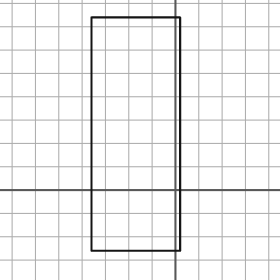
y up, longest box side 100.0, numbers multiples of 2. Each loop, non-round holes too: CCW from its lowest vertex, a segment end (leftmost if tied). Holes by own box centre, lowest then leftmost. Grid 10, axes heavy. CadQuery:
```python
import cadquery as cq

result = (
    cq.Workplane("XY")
    .moveTo(-36.0, -26.0)
    .lineTo(2.0, -26.0)
    .lineTo(2.0, 74.0)
    .lineTo(-36.0, 74.0)
    .close()
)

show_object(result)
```